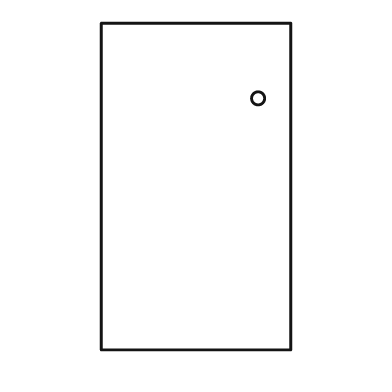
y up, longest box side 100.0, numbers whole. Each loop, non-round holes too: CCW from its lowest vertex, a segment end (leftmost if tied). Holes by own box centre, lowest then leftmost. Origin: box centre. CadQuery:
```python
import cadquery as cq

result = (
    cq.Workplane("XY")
    .moveTo(-29.0, -50.0)
    .lineTo(29.0, -50.0)
    .lineTo(29.0, 50.0)
    .lineTo(-29.0, 50.0)
    .close()
    .moveTo(19.0, 27.0)
    .circle(2.0)
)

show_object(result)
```